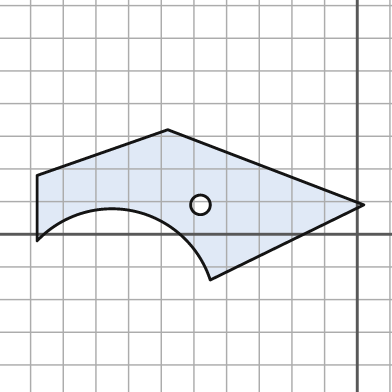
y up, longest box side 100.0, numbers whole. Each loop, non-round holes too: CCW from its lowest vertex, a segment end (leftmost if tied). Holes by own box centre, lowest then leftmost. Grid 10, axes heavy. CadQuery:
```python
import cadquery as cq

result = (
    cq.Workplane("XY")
    .moveTo(-45.0, -14.0)
    .lineTo(2.0, 9.0)
    .lineTo(-58.0, 32.0)
    .lineTo(-98.0, 18.0)
    .lineTo(-98.0, -2.0)
    .threePointArc((-68.0, 7.0), (-45.0, -14.0))
    .close()
    .moveTo(-48.0, 9.0)
    .circle(3.0)
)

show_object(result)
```